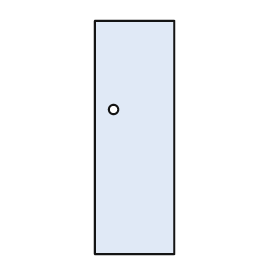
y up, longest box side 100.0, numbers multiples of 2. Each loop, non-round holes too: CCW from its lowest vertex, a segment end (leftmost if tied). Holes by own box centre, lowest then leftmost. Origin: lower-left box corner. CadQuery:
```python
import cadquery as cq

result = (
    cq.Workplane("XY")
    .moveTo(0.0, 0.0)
    .lineTo(34.0, 0.0)
    .lineTo(34.0, 100.0)
    .lineTo(0.0, 100.0)
    .close()
    .moveTo(8.0, 62.0)
    .circle(2.0)
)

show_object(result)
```